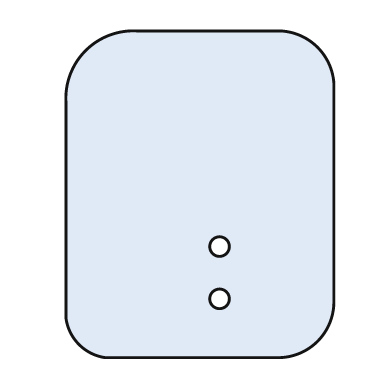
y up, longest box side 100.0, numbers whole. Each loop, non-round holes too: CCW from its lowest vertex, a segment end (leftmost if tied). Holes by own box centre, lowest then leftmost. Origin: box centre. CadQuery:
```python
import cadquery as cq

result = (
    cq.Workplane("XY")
    .moveTo(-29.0, -50.0)
    .lineTo(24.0, -50.0)
    .threePointArc((36.0, -45.0), (41.0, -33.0))
    .lineTo(41.0, 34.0)
    .threePointArc((36.0, 45.0), (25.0, 50.0))
    .lineTo(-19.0, 50.0)
    .threePointArc((-35.0, 44.0), (-41.0, 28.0))
    .lineTo(-41.0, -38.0)
    .threePointArc((-37.0, -46.0), (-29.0, -50.0))
    .close()
    .moveTo(6.0, -32.0)
    .circle(3.0)
    .moveTo(6.0, -16.0)
    .circle(3.0)
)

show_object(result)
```